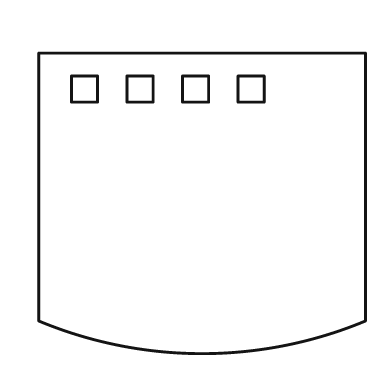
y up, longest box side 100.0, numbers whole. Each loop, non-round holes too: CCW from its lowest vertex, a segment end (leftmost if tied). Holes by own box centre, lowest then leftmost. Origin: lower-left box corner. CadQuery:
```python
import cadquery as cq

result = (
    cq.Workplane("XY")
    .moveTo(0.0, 10.0)
    .threePointArc((50.0, 0.0), (100.0, 10.0))
    .lineTo(100.0, 92.0)
    .lineTo(0.0, 92.0)
    .close()
    .moveTo(10.0, 77.0)
    .lineTo(18.0, 77.0)
    .lineTo(18.0, 85.0)
    .lineTo(10.0, 85.0)
    .close()
    .moveTo(27.0, 77.0)
    .lineTo(35.0, 77.0)
    .lineTo(35.0, 85.0)
    .lineTo(27.0, 85.0)
    .close()
    .moveTo(44.0, 77.0)
    .lineTo(52.0, 77.0)
    .lineTo(52.0, 85.0)
    .lineTo(44.0, 85.0)
    .close()
    .moveTo(61.0, 77.0)
    .lineTo(69.0, 77.0)
    .lineTo(69.0, 85.0)
    .lineTo(61.0, 85.0)
    .close()
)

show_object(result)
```